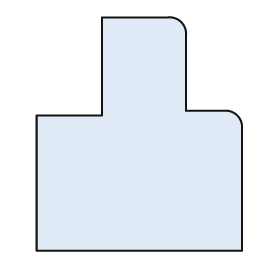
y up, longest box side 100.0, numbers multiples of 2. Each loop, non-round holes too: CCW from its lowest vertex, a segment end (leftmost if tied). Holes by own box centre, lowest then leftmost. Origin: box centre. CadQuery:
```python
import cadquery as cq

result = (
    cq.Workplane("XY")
    .moveTo(-44.0, -50.0)
    .lineTo(44.0, -50.0)
    .lineTo(44.0, 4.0)
    .threePointArc((42.0, 8.0), (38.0, 10.0))
    .lineTo(20.0, 10.0)
    .lineTo(20.0, 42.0)
    .threePointArc((18.0, 48.0), (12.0, 50.0))
    .lineTo(-16.0, 50.0)
    .lineTo(-16.0, 8.0)
    .lineTo(-44.0, 8.0)
    .close()
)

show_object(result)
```